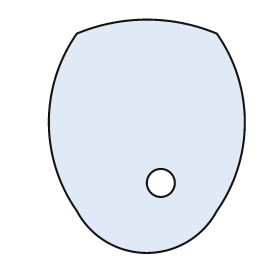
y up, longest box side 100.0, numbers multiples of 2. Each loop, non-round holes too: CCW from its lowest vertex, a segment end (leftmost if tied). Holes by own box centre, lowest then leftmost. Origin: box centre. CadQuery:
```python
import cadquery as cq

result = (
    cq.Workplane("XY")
    .moveTo(-30.0, -32.0)
    .threePointArc((0.0, -50.0), (30.0, -32.0))
    .threePointArc((42.0, 6.0), (30.0, 44.0))
    .threePointArc((0.0, 50.0), (-30.0, 44.0))
    .threePointArc((-42.0, 6.0), (-30.0, -32.0))
    .close()
    .moveTo(6.0, -20.0)
    .circle(6.0)
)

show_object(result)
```